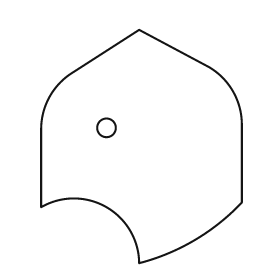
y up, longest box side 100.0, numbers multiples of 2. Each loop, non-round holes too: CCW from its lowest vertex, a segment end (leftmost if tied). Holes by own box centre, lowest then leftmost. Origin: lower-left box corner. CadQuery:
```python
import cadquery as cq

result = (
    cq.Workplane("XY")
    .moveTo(42.0, 0.0)
    .threePointArc((66.0, 10.0), (86.0, 26.0))
    .lineTo(86.0, 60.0)
    .threePointArc((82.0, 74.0), (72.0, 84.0))
    .lineTo(42.0, 100.0)
    .lineTo(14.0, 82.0)
    .threePointArc((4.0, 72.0), (0.0, 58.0))
    .lineTo(0.0, 24.0)
    .threePointArc((28.0, 24.0), (42.0, 0.0))
    .close()
    .moveTo(28.0, 58.0)
    .circle(4.0)
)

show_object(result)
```